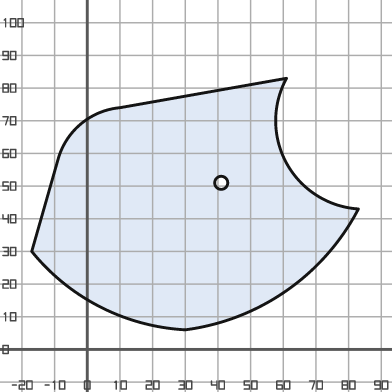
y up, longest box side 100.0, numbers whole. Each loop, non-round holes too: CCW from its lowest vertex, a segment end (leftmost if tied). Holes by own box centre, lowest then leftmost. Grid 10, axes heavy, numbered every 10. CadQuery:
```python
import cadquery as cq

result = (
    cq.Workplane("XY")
    .moveTo(30.0, 6.0)
    .threePointArc((61.0, 18.0), (83.0, 43.0))
    .threePointArc((61.0, 57.0), (61.0, 83.0))
    .lineTo(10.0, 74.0)
    .threePointArc((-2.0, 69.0), (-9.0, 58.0))
    .lineTo(-17.0, 30.0)
    .threePointArc((4.0, 13.0), (30.0, 6.0))
    .close()
    .moveTo(41.0, 51.0)
    .circle(2.0)
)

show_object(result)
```